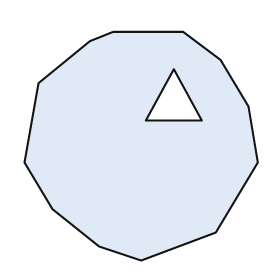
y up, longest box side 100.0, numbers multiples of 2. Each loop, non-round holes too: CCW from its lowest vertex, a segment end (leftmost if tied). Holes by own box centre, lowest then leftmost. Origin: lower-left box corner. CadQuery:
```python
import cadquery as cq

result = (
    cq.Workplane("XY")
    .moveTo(50.0, 0.0)
    .lineTo(82.0, 12.0)
    .lineTo(100.0, 42.0)
    .lineTo(96.0, 66.0)
    .lineTo(84.0, 86.0)
    .lineTo(68.0, 98.0)
    .lineTo(38.0, 98.0)
    .lineTo(28.0, 94.0)
    .lineTo(6.0, 76.0)
    .lineTo(0.0, 42.0)
    .lineTo(12.0, 22.0)
    .lineTo(32.0, 6.0)
    .close()
    .moveTo(52.0, 60.0)
    .lineTo(76.0, 60.0)
    .lineTo(64.0, 82.0)
    .close()
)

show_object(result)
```